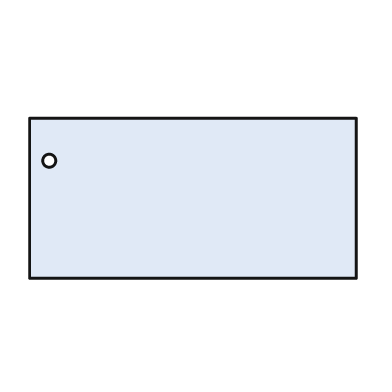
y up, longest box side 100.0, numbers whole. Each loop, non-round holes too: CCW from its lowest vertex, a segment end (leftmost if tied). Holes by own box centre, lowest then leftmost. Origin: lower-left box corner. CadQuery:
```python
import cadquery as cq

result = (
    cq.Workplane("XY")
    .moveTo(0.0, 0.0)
    .lineTo(100.0, 0.0)
    .lineTo(100.0, 49.0)
    .lineTo(0.0, 49.0)
    .close()
    .moveTo(6.0, 36.0)
    .circle(2.0)
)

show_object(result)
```